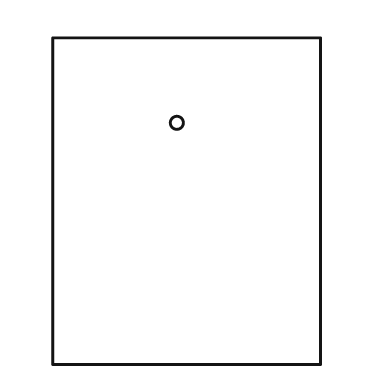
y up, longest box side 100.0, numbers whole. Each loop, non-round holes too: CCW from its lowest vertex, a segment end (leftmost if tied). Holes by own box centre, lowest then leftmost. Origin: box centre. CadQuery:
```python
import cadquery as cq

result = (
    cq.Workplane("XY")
    .moveTo(-41.0, -50.0)
    .lineTo(41.0, -50.0)
    .lineTo(41.0, 50.0)
    .lineTo(-41.0, 50.0)
    .close()
    .moveTo(-3.0, 24.0)
    .circle(2.0)
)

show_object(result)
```